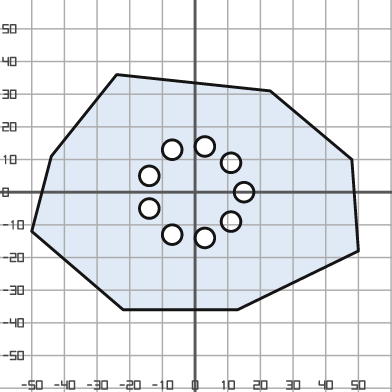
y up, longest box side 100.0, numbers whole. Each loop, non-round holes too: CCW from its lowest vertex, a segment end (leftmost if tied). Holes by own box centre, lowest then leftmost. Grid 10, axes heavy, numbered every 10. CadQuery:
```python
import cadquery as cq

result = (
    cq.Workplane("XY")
    .moveTo(-22.0, -36.0)
    .lineTo(13.0, -36.0)
    .lineTo(50.0, -18.0)
    .lineTo(48.0, 10.0)
    .lineTo(23.0, 31.0)
    .lineTo(-24.0, 36.0)
    .lineTo(-44.0, 11.0)
    .lineTo(-50.0, -12.0)
    .close()
    .moveTo(3.0, -14.0)
    .circle(3.0)
    .moveTo(-7.0, -13.0)
    .circle(3.0)
    .moveTo(11.0, -9.0)
    .circle(3.0)
    .moveTo(-14.0, -5.0)
    .circle(3.0)
    .moveTo(15.0, 0.0)
    .circle(3.0)
    .moveTo(-14.0, 5.0)
    .circle(3.0)
    .moveTo(11.0, 9.0)
    .circle(3.0)
    .moveTo(-7.0, 13.0)
    .circle(3.0)
    .moveTo(3.0, 14.0)
    .circle(3.0)
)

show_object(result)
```